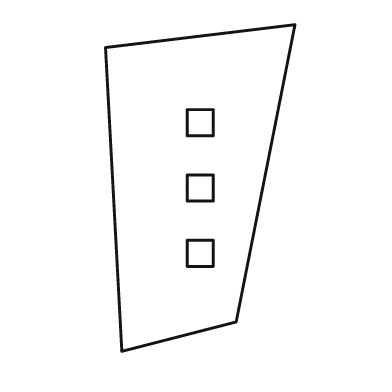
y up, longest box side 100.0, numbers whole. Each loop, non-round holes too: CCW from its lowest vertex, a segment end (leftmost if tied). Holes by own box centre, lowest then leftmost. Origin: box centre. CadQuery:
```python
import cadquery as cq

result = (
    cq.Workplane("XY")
    .moveTo(-24.0, -50.0)
    .lineTo(11.0, -41.0)
    .lineTo(29.0, 50.0)
    .lineTo(-29.0, 43.0)
    .close()
    .moveTo(-4.0, -24.0)
    .lineTo(4.0, -24.0)
    .lineTo(4.0, -16.0)
    .lineTo(-4.0, -16.0)
    .close()
    .moveTo(-4.0, -4.0)
    .lineTo(4.0, -4.0)
    .lineTo(4.0, 4.0)
    .lineTo(-4.0, 4.0)
    .close()
    .moveTo(-4.0, 16.0)
    .lineTo(4.0, 16.0)
    .lineTo(4.0, 24.0)
    .lineTo(-4.0, 24.0)
    .close()
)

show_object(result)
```